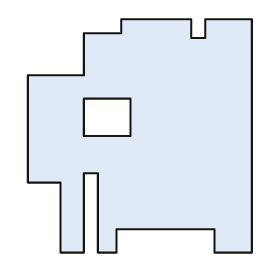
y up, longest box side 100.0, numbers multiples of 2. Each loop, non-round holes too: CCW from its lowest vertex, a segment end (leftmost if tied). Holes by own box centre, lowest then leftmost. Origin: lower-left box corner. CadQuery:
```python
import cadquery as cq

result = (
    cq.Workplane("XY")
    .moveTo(14.0, 0.0)
    .lineTo(24.0, 0.0)
    .lineTo(24.0, 34.0)
    .lineTo(30.0, 34.0)
    .lineTo(30.0, 0.0)
    .lineTo(38.0, 0.0)
    .lineTo(38.0, 10.0)
    .lineTo(80.0, 10.0)
    .lineTo(80.0, 0.0)
    .lineTo(96.0, 0.0)
    .lineTo(96.0, 100.0)
    .lineTo(76.0, 100.0)
    .lineTo(76.0, 92.0)
    .lineTo(70.0, 92.0)
    .lineTo(70.0, 100.0)
    .lineTo(40.0, 100.0)
    .lineTo(40.0, 94.0)
    .lineTo(24.0, 94.0)
    .lineTo(24.0, 76.0)
    .lineTo(0.0, 76.0)
    .lineTo(0.0, 30.0)
    .lineTo(14.0, 30.0)
    .close()
    .moveTo(24.0, 50.0)
    .lineTo(44.0, 50.0)
    .lineTo(44.0, 66.0)
    .lineTo(24.0, 66.0)
    .close()
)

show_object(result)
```